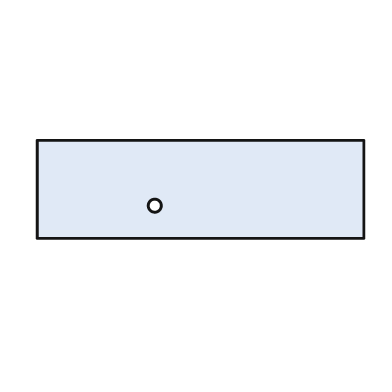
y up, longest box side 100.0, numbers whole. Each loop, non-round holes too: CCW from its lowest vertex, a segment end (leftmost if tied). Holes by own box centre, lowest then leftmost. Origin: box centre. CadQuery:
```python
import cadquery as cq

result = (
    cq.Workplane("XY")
    .moveTo(-50.0, -15.0)
    .lineTo(50.0, -15.0)
    .lineTo(50.0, 15.0)
    .lineTo(-50.0, 15.0)
    .close()
    .moveTo(-14.0, -5.0)
    .circle(2.0)
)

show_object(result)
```